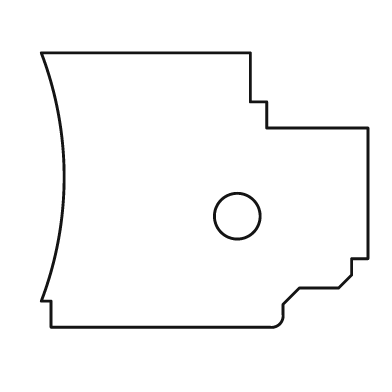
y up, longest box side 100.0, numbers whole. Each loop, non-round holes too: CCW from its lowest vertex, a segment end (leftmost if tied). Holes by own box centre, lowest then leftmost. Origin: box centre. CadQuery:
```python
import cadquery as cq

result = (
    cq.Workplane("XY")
    .moveTo(-47.0, -42.0)
    .lineTo(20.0, -42.0)
    .threePointArc((23.0, -41.0), (24.0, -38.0))
    .lineTo(24.0, -35.0)
    .lineTo(29.0, -30.0)
    .lineTo(41.0, -30.0)
    .lineTo(45.0, -26.0)
    .lineTo(45.0, -21.0)
    .lineTo(50.0, -21.0)
    .lineTo(50.0, 19.0)
    .lineTo(19.0, 19.0)
    .lineTo(19.0, 27.0)
    .lineTo(14.0, 27.0)
    .lineTo(14.0, 42.0)
    .lineTo(-50.0, 42.0)
    .threePointArc((-43.0, 4.0), (-50.0, -34.0))
    .lineTo(-47.0, -34.0)
    .close()
    .moveTo(10.0, -8.0)
    .circle(7.0)
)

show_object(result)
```